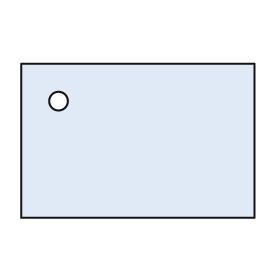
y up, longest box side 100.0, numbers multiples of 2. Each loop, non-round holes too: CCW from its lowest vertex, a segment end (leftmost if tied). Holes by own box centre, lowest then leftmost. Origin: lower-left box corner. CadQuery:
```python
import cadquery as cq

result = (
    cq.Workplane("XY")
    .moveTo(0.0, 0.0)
    .lineTo(100.0, 0.0)
    .lineTo(100.0, 66.0)
    .lineTo(0.0, 66.0)
    .close()
    .moveTo(16.0, 50.0)
    .circle(4.0)
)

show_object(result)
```